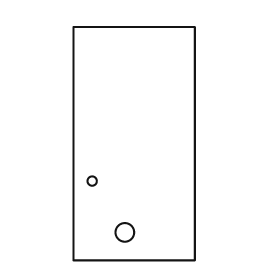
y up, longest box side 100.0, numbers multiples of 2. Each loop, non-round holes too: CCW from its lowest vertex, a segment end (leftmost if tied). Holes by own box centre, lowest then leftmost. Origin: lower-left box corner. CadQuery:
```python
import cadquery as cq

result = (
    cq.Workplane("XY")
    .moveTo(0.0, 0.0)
    .lineTo(52.0, 0.0)
    .lineTo(52.0, 100.0)
    .lineTo(0.0, 100.0)
    .close()
    .moveTo(22.0, 12.0)
    .circle(4.0)
    .moveTo(8.0, 34.0)
    .circle(2.0)
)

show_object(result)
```